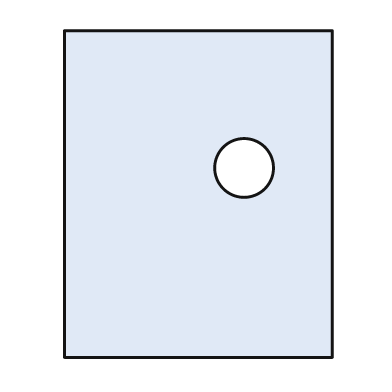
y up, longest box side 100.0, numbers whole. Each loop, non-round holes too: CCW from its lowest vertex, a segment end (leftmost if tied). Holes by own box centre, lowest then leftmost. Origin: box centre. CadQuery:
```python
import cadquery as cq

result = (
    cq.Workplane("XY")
    .moveTo(-41.0, -50.0)
    .lineTo(41.0, -50.0)
    .lineTo(41.0, 50.0)
    .lineTo(-41.0, 50.0)
    .close()
    .moveTo(14.0, 8.0)
    .circle(9.0)
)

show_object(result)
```